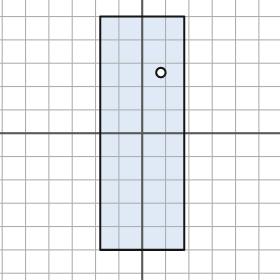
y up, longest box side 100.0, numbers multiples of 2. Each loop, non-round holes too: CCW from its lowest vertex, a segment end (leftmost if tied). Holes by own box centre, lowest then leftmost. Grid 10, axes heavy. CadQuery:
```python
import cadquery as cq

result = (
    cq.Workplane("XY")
    .moveTo(-18.0, -50.0)
    .lineTo(18.0, -50.0)
    .lineTo(18.0, 50.0)
    .lineTo(-18.0, 50.0)
    .close()
    .moveTo(8.0, 26.0)
    .circle(2.0)
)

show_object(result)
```